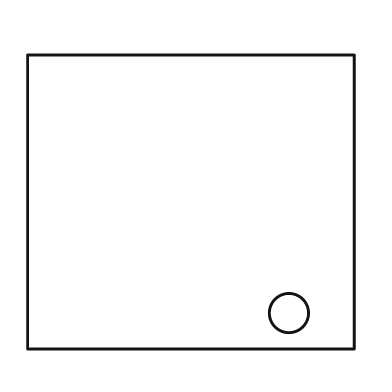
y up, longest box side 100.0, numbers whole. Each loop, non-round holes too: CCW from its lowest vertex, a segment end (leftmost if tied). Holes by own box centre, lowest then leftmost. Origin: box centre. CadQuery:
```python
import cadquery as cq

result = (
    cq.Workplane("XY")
    .moveTo(-50.0, -45.0)
    .lineTo(50.0, -45.0)
    .lineTo(50.0, 45.0)
    .lineTo(-50.0, 45.0)
    .close()
    .moveTo(30.0, -34.0)
    .circle(6.0)
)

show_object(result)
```